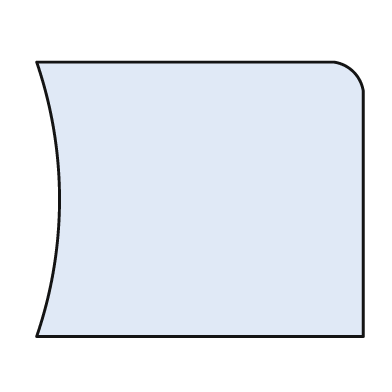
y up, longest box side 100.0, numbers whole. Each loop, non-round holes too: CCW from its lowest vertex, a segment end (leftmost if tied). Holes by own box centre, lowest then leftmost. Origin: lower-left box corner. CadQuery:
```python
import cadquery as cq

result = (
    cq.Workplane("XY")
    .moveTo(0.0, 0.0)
    .lineTo(100.0, 0.0)
    .lineTo(100.0, 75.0)
    .threePointArc((97.0, 81.0), (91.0, 84.0))
    .lineTo(0.0, 84.0)
    .threePointArc((7.0, 42.0), (0.0, 0.0))
    .close()
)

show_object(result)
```